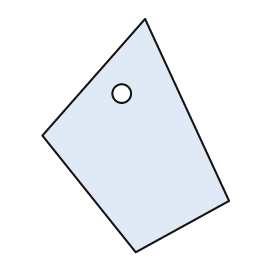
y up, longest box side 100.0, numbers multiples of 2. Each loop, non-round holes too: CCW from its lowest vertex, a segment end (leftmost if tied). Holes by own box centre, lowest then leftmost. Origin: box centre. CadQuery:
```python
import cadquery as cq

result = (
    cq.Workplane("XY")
    .moveTo(0.0, -50.0)
    .lineTo(40.0, -28.0)
    .lineTo(4.0, 50.0)
    .lineTo(-40.0, 0.0)
    .close()
    .moveTo(-6.0, 18.0)
    .circle(4.0)
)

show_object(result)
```